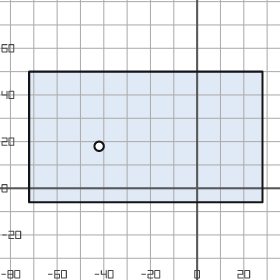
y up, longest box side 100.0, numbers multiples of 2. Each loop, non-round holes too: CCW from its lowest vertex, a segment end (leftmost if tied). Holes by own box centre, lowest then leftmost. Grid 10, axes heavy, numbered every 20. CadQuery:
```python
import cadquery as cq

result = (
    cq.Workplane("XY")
    .moveTo(-72.0, -6.0)
    .lineTo(28.0, -6.0)
    .lineTo(28.0, 50.0)
    .lineTo(-72.0, 50.0)
    .close()
    .moveTo(-42.0, 18.0)
    .circle(2.0)
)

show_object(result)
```